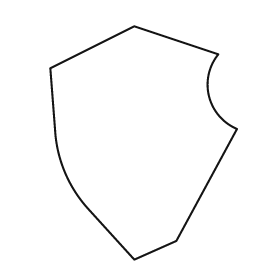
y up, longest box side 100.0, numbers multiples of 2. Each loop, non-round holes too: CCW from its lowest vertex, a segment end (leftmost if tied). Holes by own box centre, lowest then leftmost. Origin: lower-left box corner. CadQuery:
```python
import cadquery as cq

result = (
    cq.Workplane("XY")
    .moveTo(36.0, 0.0)
    .lineTo(54.0, 8.0)
    .lineTo(80.0, 56.0)
    .threePointArc((68.0, 70.0), (72.0, 88.0))
    .lineTo(36.0, 100.0)
    .lineTo(0.0, 82.0)
    .lineTo(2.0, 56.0)
    .threePointArc((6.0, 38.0), (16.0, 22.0))
    .close()
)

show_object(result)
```